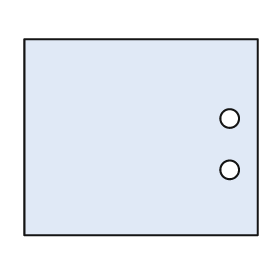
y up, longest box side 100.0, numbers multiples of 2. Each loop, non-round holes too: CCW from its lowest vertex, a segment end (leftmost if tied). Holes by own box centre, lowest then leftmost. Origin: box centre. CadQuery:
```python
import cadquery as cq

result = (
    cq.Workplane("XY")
    .moveTo(-50.0, -42.0)
    .lineTo(50.0, -42.0)
    .lineTo(50.0, 42.0)
    .lineTo(-50.0, 42.0)
    .close()
    .moveTo(38.0, -14.0)
    .circle(4.0)
    .moveTo(38.0, 8.0)
    .circle(4.0)
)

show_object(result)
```